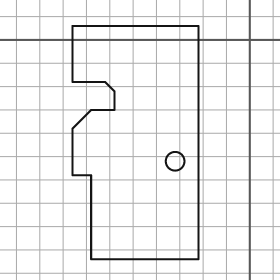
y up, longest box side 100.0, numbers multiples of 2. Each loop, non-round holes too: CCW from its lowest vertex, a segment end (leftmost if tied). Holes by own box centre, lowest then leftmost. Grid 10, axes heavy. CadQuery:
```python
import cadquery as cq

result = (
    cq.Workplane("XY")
    .moveTo(-68.0, -94.0)
    .lineTo(-22.0, -94.0)
    .lineTo(-22.0, 6.0)
    .lineTo(-76.0, 6.0)
    .lineTo(-76.0, -18.0)
    .lineTo(-62.0, -18.0)
    .lineTo(-58.0, -22.0)
    .lineTo(-58.0, -30.0)
    .lineTo(-68.0, -30.0)
    .lineTo(-76.0, -38.0)
    .lineTo(-76.0, -58.0)
    .lineTo(-68.0, -58.0)
    .close()
    .moveTo(-32.0, -52.0)
    .circle(4.0)
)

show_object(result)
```